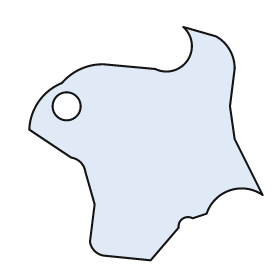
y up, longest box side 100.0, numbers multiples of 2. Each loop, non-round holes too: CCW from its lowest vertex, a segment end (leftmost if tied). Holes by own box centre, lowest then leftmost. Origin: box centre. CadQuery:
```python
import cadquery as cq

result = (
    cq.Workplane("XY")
    .moveTo(2.0, -50.0)
    .lineTo(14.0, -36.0)
    .threePointArc((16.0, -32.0), (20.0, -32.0))
    .lineTo(26.0, -30.0)
    .threePointArc((36.0, -20.0), (50.0, -22.0))
    .lineTo(38.0, 2.0)
    .lineTo(36.0, 16.0)
    .lineTo(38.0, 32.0)
    .threePointArc((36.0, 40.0), (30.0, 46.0))
    .lineTo(16.0, 50.0)
    .threePointArc((18.0, 36.0), (4.0, 32.0))
    .lineTo(-18.0, 34.0)
    .threePointArc((-28.0, 32.0), (-36.0, 26.0))
    .threePointArc((-46.0, 18.0), (-50.0, 6.0))
    .lineTo(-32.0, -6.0)
    .threePointArc((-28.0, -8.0), (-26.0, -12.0))
    .lineTo(-22.0, -26.0)
    .lineTo(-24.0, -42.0)
    .threePointArc((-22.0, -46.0), (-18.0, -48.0))
    .close()
    .moveTo(-34.0, 16.0)
    .circle(6.0)
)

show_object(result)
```